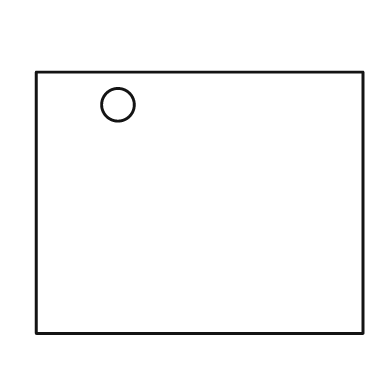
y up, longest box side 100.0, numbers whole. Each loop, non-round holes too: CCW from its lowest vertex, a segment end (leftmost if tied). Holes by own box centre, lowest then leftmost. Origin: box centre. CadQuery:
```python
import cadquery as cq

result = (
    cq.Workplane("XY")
    .moveTo(-50.0, -40.0)
    .lineTo(50.0, -40.0)
    .lineTo(50.0, 40.0)
    .lineTo(-50.0, 40.0)
    .close()
    .moveTo(-25.0, 30.0)
    .circle(5.0)
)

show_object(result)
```